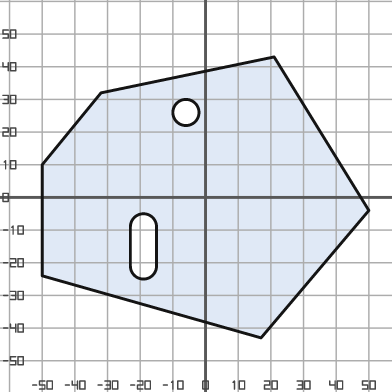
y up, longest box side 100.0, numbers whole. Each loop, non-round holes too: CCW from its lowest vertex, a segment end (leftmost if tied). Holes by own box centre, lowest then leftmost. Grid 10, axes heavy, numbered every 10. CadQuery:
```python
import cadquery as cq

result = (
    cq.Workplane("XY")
    .moveTo(17.0, -43.0)
    .lineTo(50.0, -4.0)
    .lineTo(21.0, 43.0)
    .lineTo(-32.0, 32.0)
    .lineTo(-50.0, 10.0)
    .lineTo(-50.0, -24.0)
    .close()
    .moveTo(-23.0, -21.0)
    .threePointArc((-19.0, -25.0), (-15.0, -21.0))
    .lineTo(-15.0, -9.0)
    .threePointArc((-19.0, -5.0), (-23.0, -9.0))
    .close()
    .moveTo(-6.0, 26.0)
    .circle(4.0)
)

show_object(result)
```